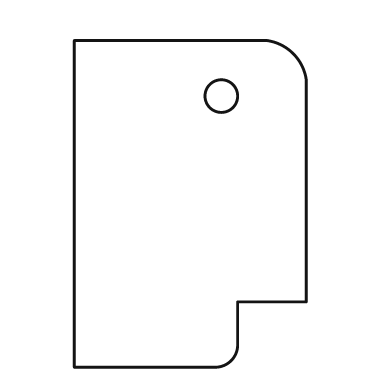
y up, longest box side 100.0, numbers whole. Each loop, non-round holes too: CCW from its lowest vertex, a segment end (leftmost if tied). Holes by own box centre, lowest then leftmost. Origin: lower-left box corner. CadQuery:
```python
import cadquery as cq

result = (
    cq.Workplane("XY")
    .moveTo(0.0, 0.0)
    .lineTo(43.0, 0.0)
    .threePointArc((48.0, 2.0), (50.0, 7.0))
    .lineTo(50.0, 20.0)
    .lineTo(71.0, 20.0)
    .lineTo(71.0, 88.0)
    .threePointArc((67.0, 96.0), (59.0, 100.0))
    .lineTo(0.0, 100.0)
    .close()
    .moveTo(45.0, 83.0)
    .circle(5.0)
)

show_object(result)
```